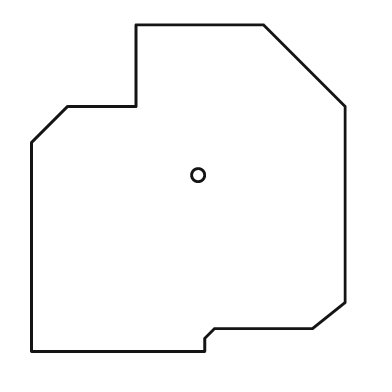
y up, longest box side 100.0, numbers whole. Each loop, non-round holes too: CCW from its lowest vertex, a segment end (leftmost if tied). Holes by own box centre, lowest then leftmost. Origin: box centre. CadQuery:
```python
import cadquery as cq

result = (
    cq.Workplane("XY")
    .moveTo(-48.0, -50.0)
    .lineTo(5.0, -50.0)
    .lineTo(5.0, -46.0)
    .lineTo(8.0, -43.0)
    .lineTo(38.0, -43.0)
    .lineTo(48.0, -35.0)
    .lineTo(48.0, 25.0)
    .lineTo(23.0, 50.0)
    .lineTo(-16.0, 50.0)
    .lineTo(-16.0, 25.0)
    .lineTo(-37.0, 25.0)
    .lineTo(-48.0, 14.0)
    .close()
    .moveTo(3.0, 4.0)
    .circle(2.0)
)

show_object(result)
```